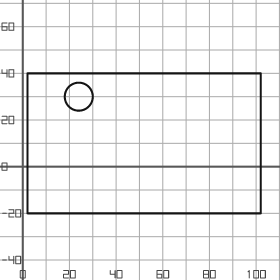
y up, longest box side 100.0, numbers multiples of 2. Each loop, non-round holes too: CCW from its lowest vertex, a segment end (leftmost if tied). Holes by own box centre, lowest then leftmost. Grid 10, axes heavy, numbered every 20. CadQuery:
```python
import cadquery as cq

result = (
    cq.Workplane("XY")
    .moveTo(2.0, -20.0)
    .lineTo(102.0, -20.0)
    .lineTo(102.0, 40.0)
    .lineTo(2.0, 40.0)
    .close()
    .moveTo(24.0, 30.0)
    .circle(6.0)
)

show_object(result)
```